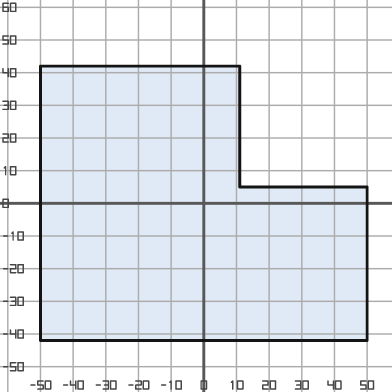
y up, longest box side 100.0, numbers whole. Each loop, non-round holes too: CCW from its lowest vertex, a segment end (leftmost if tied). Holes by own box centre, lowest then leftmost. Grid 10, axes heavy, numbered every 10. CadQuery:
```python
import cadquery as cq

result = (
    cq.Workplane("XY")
    .moveTo(-50.0, -42.0)
    .lineTo(50.0, -42.0)
    .lineTo(50.0, 5.0)
    .lineTo(11.0, 5.0)
    .lineTo(11.0, 42.0)
    .lineTo(-50.0, 42.0)
    .close()
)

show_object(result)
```